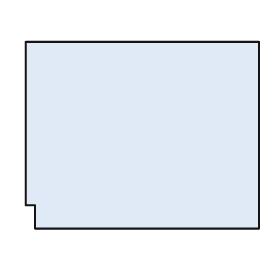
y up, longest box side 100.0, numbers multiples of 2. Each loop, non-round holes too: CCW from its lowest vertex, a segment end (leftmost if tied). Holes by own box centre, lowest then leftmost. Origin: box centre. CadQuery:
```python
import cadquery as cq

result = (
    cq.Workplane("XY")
    .moveTo(-46.0, -40.0)
    .lineTo(50.0, -40.0)
    .lineTo(50.0, 40.0)
    .lineTo(-50.0, 40.0)
    .lineTo(-50.0, -30.0)
    .lineTo(-46.0, -30.0)
    .close()
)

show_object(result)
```